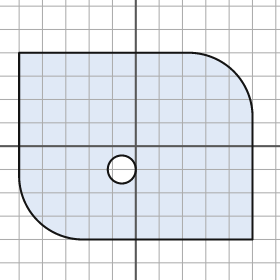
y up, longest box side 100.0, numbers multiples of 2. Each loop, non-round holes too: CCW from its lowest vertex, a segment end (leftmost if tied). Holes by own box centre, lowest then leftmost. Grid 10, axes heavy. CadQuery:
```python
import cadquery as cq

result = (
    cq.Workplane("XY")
    .moveTo(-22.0, -40.0)
    .lineTo(50.0, -40.0)
    .lineTo(50.0, 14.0)
    .threePointArc((42.0, 32.0), (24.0, 40.0))
    .lineTo(-50.0, 40.0)
    .lineTo(-50.0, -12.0)
    .threePointArc((-42.0, -32.0), (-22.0, -40.0))
    .close()
    .moveTo(-6.0, -10.0)
    .circle(6.0)
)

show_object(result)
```